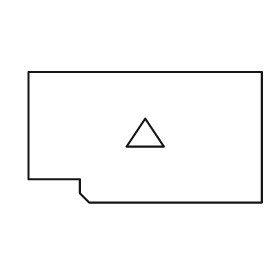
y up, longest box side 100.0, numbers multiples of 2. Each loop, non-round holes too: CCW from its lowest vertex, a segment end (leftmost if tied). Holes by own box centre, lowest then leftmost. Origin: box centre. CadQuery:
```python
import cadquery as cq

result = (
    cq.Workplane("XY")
    .moveTo(-24.0, -28.0)
    .lineTo(50.0, -28.0)
    .lineTo(50.0, 28.0)
    .lineTo(-50.0, 28.0)
    .lineTo(-50.0, -18.0)
    .lineTo(-28.0, -18.0)
    .lineTo(-28.0, -24.0)
    .close()
    .moveTo(-8.0, -4.0)
    .lineTo(8.0, -4.0)
    .lineTo(0.0, 8.0)
    .close()
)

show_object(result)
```